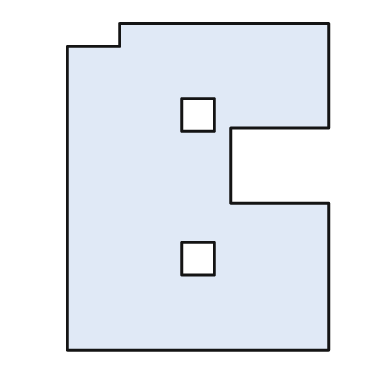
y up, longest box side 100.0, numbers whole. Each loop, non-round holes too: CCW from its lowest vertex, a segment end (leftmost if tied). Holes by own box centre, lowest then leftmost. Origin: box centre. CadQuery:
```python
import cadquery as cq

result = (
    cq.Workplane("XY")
    .moveTo(-40.0, -50.0)
    .lineTo(40.0, -50.0)
    .lineTo(40.0, -5.0)
    .lineTo(10.0, -5.0)
    .lineTo(10.0, 18.0)
    .lineTo(40.0, 18.0)
    .lineTo(40.0, 50.0)
    .lineTo(-24.0, 50.0)
    .lineTo(-24.0, 43.0)
    .lineTo(-40.0, 43.0)
    .close()
    .moveTo(-5.0, -27.0)
    .lineTo(5.0, -27.0)
    .lineTo(5.0, -17.0)
    .lineTo(-5.0, -17.0)
    .close()
    .moveTo(-5.0, 17.0)
    .lineTo(5.0, 17.0)
    .lineTo(5.0, 27.0)
    .lineTo(-5.0, 27.0)
    .close()
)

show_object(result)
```